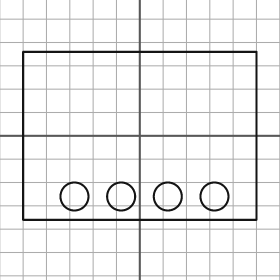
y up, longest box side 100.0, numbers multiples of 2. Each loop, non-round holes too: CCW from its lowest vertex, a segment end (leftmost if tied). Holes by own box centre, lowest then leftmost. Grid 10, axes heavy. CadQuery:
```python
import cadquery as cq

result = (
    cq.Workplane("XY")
    .moveTo(-50.0, -36.0)
    .lineTo(50.0, -36.0)
    .lineTo(50.0, 36.0)
    .lineTo(-50.0, 36.0)
    .close()
    .moveTo(-28.0, -26.0)
    .circle(6.0)
    .moveTo(-8.0, -26.0)
    .circle(6.0)
    .moveTo(12.0, -26.0)
    .circle(6.0)
    .moveTo(32.0, -26.0)
    .circle(6.0)
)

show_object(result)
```